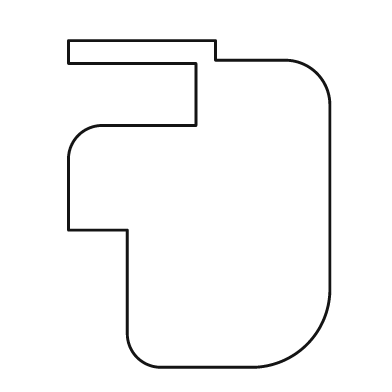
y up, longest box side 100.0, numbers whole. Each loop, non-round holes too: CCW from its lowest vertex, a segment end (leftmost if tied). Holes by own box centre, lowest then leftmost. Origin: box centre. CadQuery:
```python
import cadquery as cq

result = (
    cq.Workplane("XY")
    .moveTo(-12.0, -50.0)
    .lineTo(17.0, -50.0)
    .threePointArc((33.0, -43.0), (40.0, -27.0))
    .lineTo(40.0, 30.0)
    .threePointArc((36.0, 40.0), (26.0, 44.0))
    .lineTo(5.0, 44.0)
    .lineTo(5.0, 50.0)
    .lineTo(-40.0, 50.0)
    .lineTo(-40.0, 43.0)
    .lineTo(-1.0, 43.0)
    .lineTo(-1.0, 24.0)
    .lineTo(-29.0, 24.0)
    .threePointArc((-37.0, 21.0), (-40.0, 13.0))
    .lineTo(-40.0, -8.0)
    .lineTo(-22.0, -8.0)
    .lineTo(-22.0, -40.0)
    .threePointArc((-19.0, -47.0), (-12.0, -50.0))
    .close()
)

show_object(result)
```